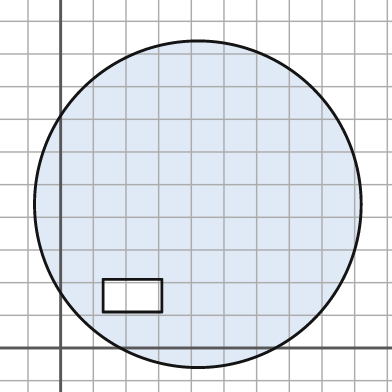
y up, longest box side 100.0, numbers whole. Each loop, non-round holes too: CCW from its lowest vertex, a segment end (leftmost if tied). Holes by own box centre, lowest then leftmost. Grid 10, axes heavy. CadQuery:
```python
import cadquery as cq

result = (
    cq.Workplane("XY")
    .moveTo(42.0, 44.0)
    .circle(50.0)
    .moveTo(13.0, 11.0)
    .lineTo(31.0, 11.0)
    .lineTo(31.0, 21.0)
    .lineTo(13.0, 21.0)
    .close()
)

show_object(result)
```